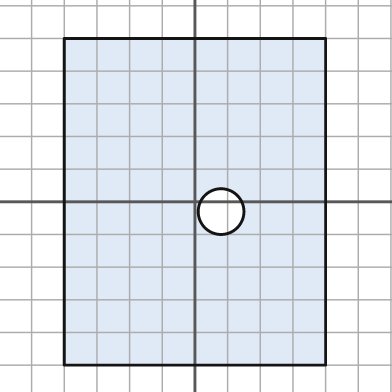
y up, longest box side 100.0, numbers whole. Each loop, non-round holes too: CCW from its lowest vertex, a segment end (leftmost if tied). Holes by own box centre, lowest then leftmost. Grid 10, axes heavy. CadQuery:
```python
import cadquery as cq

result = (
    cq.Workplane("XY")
    .moveTo(-40.0, -50.0)
    .lineTo(40.0, -50.0)
    .lineTo(40.0, 50.0)
    .lineTo(-40.0, 50.0)
    .close()
    .moveTo(8.0, -3.0)
    .circle(7.0)
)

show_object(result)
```